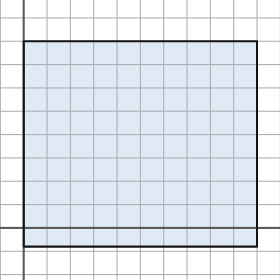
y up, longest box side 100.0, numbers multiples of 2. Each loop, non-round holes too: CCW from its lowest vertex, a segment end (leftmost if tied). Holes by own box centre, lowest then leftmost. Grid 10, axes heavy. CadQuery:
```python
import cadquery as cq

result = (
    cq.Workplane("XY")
    .moveTo(0.0, -8.0)
    .lineTo(100.0, -8.0)
    .lineTo(100.0, 80.0)
    .lineTo(0.0, 80.0)
    .close()
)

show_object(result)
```